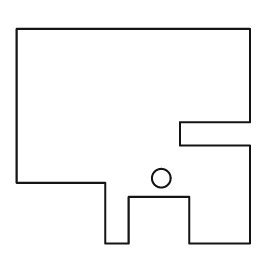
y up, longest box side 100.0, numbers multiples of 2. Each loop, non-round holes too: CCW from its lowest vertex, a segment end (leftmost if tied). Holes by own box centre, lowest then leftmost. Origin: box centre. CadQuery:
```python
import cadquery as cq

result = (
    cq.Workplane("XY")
    .moveTo(-12.0, -46.0)
    .lineTo(-2.0, -46.0)
    .lineTo(-2.0, -26.0)
    .lineTo(24.0, -26.0)
    .lineTo(24.0, -46.0)
    .lineTo(50.0, -46.0)
    .lineTo(50.0, -4.0)
    .lineTo(20.0, -4.0)
    .lineTo(20.0, 6.0)
    .lineTo(50.0, 6.0)
    .lineTo(50.0, 46.0)
    .lineTo(-50.0, 46.0)
    .lineTo(-50.0, -20.0)
    .lineTo(-12.0, -20.0)
    .close()
    .moveTo(12.0, -18.0)
    .circle(4.0)
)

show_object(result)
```